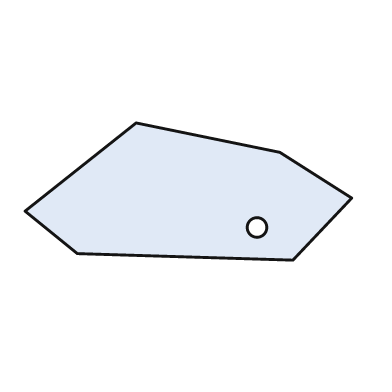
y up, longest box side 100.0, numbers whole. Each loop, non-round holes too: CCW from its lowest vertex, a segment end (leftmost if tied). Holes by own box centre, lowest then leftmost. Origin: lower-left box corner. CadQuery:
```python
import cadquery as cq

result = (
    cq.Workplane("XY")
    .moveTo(82.0, 0.0)
    .lineTo(100.0, 19.0)
    .lineTo(78.0, 33.0)
    .lineTo(34.0, 42.0)
    .lineTo(0.0, 15.0)
    .lineTo(16.0, 2.0)
    .close()
    .moveTo(71.0, 10.0)
    .circle(3.0)
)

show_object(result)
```